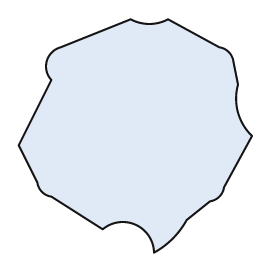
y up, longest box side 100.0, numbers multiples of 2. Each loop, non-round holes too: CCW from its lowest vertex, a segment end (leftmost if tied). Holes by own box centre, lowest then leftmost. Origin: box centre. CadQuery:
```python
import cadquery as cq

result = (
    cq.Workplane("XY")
    .moveTo(8.0, -50.0)
    .threePointArc((16.0, -44.0), (22.0, -36.0))
    .lineTo(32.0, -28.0)
    .threePointArc((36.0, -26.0), (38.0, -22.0))
    .lineTo(50.0, 0.0)
    .threePointArc((44.0, 10.0), (44.0, 22.0))
    .lineTo(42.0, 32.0)
    .threePointArc((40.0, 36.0), (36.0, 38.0))
    .lineTo(14.0, 50.0)
    .threePointArc((6.0, 48.0), (-2.0, 50.0))
    .lineTo(-32.0, 38.0)
    .threePointArc((-38.0, 32.0), (-36.0, 24.0))
    .lineTo(-50.0, -4.0)
    .lineTo(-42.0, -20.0)
    .threePointArc((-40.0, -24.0), (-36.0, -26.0))
    .lineTo(-14.0, -40.0)
    .threePointArc((0.0, -38.0), (8.0, -50.0))
    .close()
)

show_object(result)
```